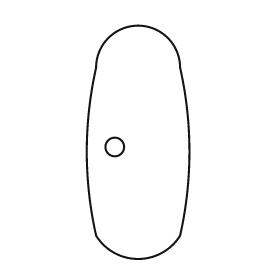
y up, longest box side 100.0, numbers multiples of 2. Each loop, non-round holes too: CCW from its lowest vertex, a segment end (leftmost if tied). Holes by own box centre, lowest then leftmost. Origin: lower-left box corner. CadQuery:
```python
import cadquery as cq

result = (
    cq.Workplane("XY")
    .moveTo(4.0, 10.0)
    .threePointArc((22.0, 0.0), (40.0, 10.0))
    .threePointArc((44.0, 46.0), (40.0, 82.0))
    .threePointArc((22.0, 100.0), (4.0, 82.0))
    .threePointArc((0.0, 46.0), (4.0, 10.0))
    .close()
    .moveTo(12.0, 48.0)
    .circle(4.0)
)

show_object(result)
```